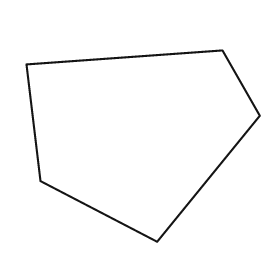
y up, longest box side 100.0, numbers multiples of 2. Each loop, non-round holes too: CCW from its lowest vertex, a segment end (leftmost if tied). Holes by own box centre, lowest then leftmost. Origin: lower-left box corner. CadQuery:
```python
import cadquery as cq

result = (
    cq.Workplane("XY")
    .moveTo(56.0, 0.0)
    .lineTo(100.0, 54.0)
    .lineTo(84.0, 82.0)
    .lineTo(0.0, 76.0)
    .lineTo(6.0, 26.0)
    .close()
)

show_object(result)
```